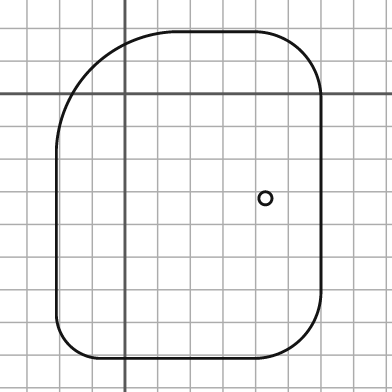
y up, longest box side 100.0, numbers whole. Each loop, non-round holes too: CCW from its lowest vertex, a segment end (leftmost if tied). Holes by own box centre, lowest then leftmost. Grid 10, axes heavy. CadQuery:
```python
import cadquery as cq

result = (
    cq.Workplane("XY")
    .moveTo(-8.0, -81.0)
    .lineTo(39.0, -81.0)
    .threePointArc((54.0, -75.0), (60.0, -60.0))
    .lineTo(60.0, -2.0)
    .threePointArc((54.0, 13.0), (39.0, 19.0))
    .lineTo(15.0, 19.0)
    .threePointArc((-10.0, 8.0), (-21.0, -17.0))
    .lineTo(-21.0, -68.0)
    .threePointArc((-17.0, -77.0), (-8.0, -81.0))
    .close()
    .moveTo(43.0, -32.0)
    .circle(2.0)
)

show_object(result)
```